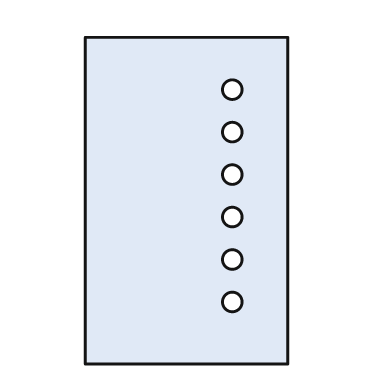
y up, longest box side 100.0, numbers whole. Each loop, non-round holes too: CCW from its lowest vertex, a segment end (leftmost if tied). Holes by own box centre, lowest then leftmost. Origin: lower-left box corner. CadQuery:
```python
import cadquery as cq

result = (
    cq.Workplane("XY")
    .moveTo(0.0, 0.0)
    .lineTo(62.0, 0.0)
    .lineTo(62.0, 100.0)
    .lineTo(0.0, 100.0)
    .close()
    .moveTo(45.0, 19.0)
    .circle(3.0)
    .moveTo(45.0, 32.0)
    .circle(3.0)
    .moveTo(45.0, 45.0)
    .circle(3.0)
    .moveTo(45.0, 58.0)
    .circle(3.0)
    .moveTo(45.0, 71.0)
    .circle(3.0)
    .moveTo(45.0, 84.0)
    .circle(3.0)
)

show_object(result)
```